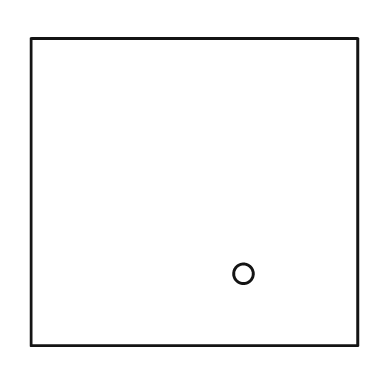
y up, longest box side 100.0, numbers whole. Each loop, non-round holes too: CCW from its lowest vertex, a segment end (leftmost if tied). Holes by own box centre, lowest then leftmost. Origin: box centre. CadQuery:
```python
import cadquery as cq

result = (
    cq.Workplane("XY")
    .moveTo(-50.0, -47.0)
    .lineTo(50.0, -47.0)
    .lineTo(50.0, 47.0)
    .lineTo(-50.0, 47.0)
    .close()
    .moveTo(15.0, -25.0)
    .circle(3.0)
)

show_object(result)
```